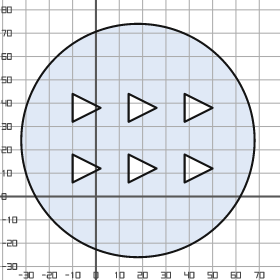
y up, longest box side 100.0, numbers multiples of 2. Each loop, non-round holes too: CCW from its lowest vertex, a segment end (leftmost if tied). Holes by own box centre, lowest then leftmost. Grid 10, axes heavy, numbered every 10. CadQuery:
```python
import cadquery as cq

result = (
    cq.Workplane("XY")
    .moveTo(18.0, 24.0)
    .circle(50.0)
    .moveTo(-10.0, 6.0)
    .lineTo(2.0, 12.0)
    .lineTo(-10.0, 18.0)
    .close()
    .moveTo(14.0, 6.0)
    .lineTo(26.0, 12.0)
    .lineTo(14.0, 18.0)
    .close()
    .moveTo(38.0, 6.0)
    .lineTo(50.0, 12.0)
    .lineTo(38.0, 18.0)
    .close()
    .moveTo(-10.0, 32.0)
    .lineTo(2.0, 38.0)
    .lineTo(-10.0, 44.0)
    .close()
    .moveTo(14.0, 32.0)
    .lineTo(26.0, 38.0)
    .lineTo(14.0, 44.0)
    .close()
    .moveTo(38.0, 32.0)
    .lineTo(50.0, 38.0)
    .lineTo(38.0, 44.0)
    .close()
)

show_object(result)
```